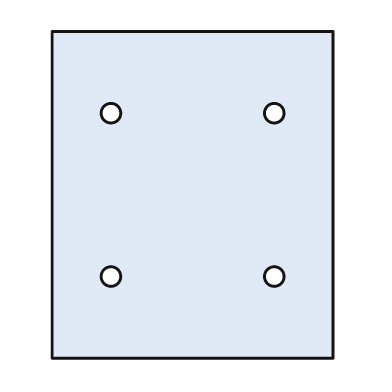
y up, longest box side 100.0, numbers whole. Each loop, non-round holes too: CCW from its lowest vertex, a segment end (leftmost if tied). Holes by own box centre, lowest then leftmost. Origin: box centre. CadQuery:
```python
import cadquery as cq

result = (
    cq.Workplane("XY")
    .moveTo(-43.0, -50.0)
    .lineTo(43.0, -50.0)
    .lineTo(43.0, 50.0)
    .lineTo(-43.0, 50.0)
    .close()
    .moveTo(-25.0, -25.0)
    .circle(3.0)
    .moveTo(25.0, -25.0)
    .circle(3.0)
    .moveTo(-25.0, 25.0)
    .circle(3.0)
    .moveTo(25.0, 25.0)
    .circle(3.0)
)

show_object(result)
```